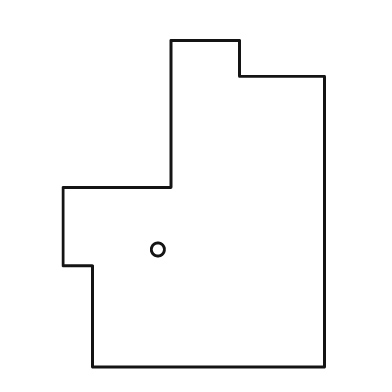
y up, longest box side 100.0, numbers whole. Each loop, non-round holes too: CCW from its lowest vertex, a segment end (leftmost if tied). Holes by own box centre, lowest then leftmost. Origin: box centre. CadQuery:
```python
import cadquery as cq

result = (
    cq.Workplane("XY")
    .moveTo(-31.0, -50.0)
    .lineTo(40.0, -50.0)
    .lineTo(40.0, 39.0)
    .lineTo(14.0, 39.0)
    .lineTo(14.0, 50.0)
    .lineTo(-7.0, 50.0)
    .lineTo(-7.0, 5.0)
    .lineTo(-40.0, 5.0)
    .lineTo(-40.0, -19.0)
    .lineTo(-31.0, -19.0)
    .close()
    .moveTo(-11.0, -14.0)
    .circle(2.0)
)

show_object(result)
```